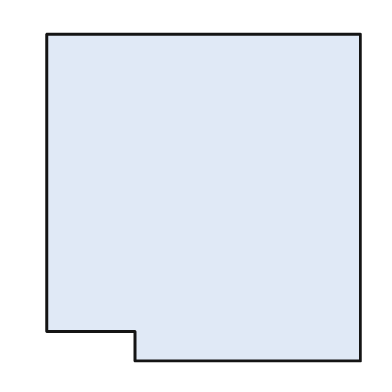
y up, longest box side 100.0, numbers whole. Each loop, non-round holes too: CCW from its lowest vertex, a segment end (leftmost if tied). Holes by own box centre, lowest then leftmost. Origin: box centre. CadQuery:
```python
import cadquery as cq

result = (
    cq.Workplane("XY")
    .moveTo(-21.0, -50.0)
    .lineTo(48.0, -50.0)
    .lineTo(48.0, 50.0)
    .lineTo(-48.0, 50.0)
    .lineTo(-48.0, -41.0)
    .lineTo(-21.0, -41.0)
    .close()
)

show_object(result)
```